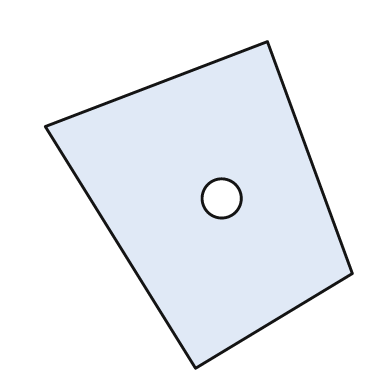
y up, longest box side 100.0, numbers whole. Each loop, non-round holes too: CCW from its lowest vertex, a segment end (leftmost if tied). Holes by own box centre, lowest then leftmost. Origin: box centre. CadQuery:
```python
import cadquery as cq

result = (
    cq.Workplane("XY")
    .moveTo(-1.0, -50.0)
    .lineTo(47.0, -21.0)
    .lineTo(21.0, 50.0)
    .lineTo(-47.0, 24.0)
    .close()
    .moveTo(7.0, 2.0)
    .circle(6.0)
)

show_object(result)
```